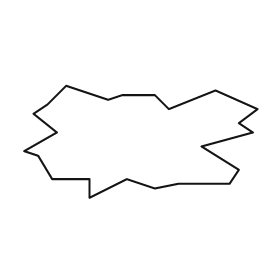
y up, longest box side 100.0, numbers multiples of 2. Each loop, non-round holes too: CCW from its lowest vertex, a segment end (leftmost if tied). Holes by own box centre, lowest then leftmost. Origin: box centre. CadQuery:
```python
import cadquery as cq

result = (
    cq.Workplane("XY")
    .moveTo(-22.0, -24.0)
    .lineTo(-6.0, -16.0)
    .lineTo(6.0, -20.0)
    .lineTo(16.0, -18.0)
    .lineTo(38.0, -18.0)
    .lineTo(42.0, -12.0)
    .lineTo(26.0, -2.0)
    .lineTo(48.0, 4.0)
    .lineTo(42.0, 8.0)
    .lineTo(50.0, 14.0)
    .lineTo(32.0, 22.0)
    .lineTo(12.0, 14.0)
    .lineTo(6.0, 20.0)
    .lineTo(-8.0, 20.0)
    .lineTo(-14.0, 18.0)
    .lineTo(-32.0, 24.0)
    .lineTo(-40.0, 16.0)
    .lineTo(-46.0, 12.0)
    .lineTo(-36.0, 4.0)
    .lineTo(-50.0, -4.0)
    .lineTo(-44.0, -6.0)
    .lineTo(-38.0, -16.0)
    .lineTo(-22.0, -16.0)
    .close()
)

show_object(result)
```